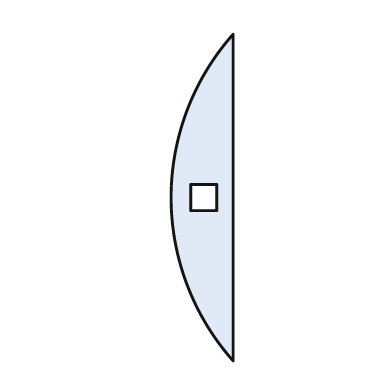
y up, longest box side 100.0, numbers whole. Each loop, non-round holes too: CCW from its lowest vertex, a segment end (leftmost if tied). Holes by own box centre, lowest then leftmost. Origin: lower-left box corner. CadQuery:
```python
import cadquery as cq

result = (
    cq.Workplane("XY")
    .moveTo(19.0, 0.0)
    .lineTo(19.0, 100.0)
    .threePointArc((0.0, 50.0), (19.0, 0.0))
    .close()
    .moveTo(6.0, 46.0)
    .lineTo(14.0, 46.0)
    .lineTo(14.0, 54.0)
    .lineTo(6.0, 54.0)
    .close()
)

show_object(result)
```